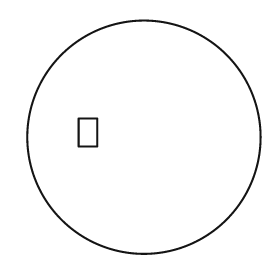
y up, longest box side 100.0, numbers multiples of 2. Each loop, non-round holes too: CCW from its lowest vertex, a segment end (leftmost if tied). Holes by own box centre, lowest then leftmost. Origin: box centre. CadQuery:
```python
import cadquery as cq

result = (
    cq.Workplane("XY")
    .moveTo(0.0, 0.0)
    .circle(50.0)
    .moveTo(-28.0, -4.0)
    .lineTo(-20.0, -4.0)
    .lineTo(-20.0, 8.0)
    .lineTo(-28.0, 8.0)
    .close()
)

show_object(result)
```